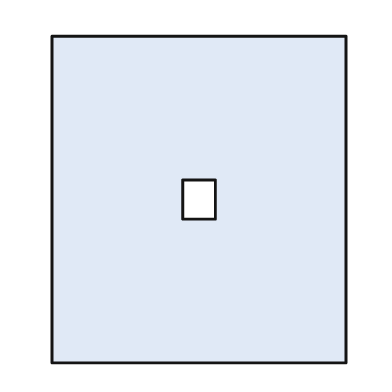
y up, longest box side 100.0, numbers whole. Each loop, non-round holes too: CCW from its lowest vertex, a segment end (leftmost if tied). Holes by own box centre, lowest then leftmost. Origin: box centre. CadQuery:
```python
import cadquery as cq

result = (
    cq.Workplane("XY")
    .moveTo(-45.0, -50.0)
    .lineTo(45.0, -50.0)
    .lineTo(45.0, 50.0)
    .lineTo(-45.0, 50.0)
    .close()
    .moveTo(-5.0, -6.0)
    .lineTo(5.0, -6.0)
    .lineTo(5.0, 6.0)
    .lineTo(-5.0, 6.0)
    .close()
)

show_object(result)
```